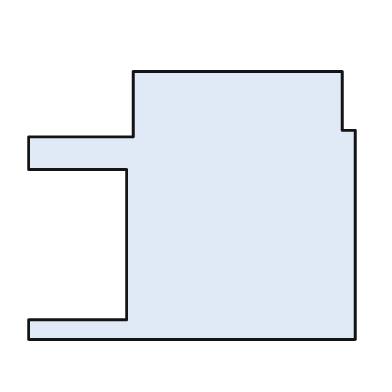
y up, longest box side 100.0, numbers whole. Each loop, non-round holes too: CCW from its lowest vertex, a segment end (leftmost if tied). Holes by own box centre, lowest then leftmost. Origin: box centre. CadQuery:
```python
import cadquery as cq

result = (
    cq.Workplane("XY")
    .moveTo(-50.0, -41.0)
    .lineTo(50.0, -41.0)
    .lineTo(50.0, 23.0)
    .lineTo(46.0, 23.0)
    .lineTo(46.0, 41.0)
    .lineTo(-18.0, 41.0)
    .lineTo(-18.0, 21.0)
    .lineTo(-50.0, 21.0)
    .lineTo(-50.0, 11.0)
    .lineTo(-20.0, 11.0)
    .lineTo(-20.0, -35.0)
    .lineTo(-50.0, -35.0)
    .close()
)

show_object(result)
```